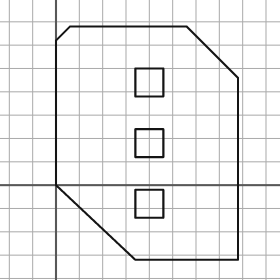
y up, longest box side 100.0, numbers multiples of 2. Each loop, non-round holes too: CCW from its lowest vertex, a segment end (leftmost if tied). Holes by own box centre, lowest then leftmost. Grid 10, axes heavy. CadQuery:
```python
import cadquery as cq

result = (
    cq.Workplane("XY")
    .moveTo(34.0, -32.0)
    .lineTo(78.0, -32.0)
    .lineTo(78.0, 46.0)
    .lineTo(56.0, 68.0)
    .lineTo(6.0, 68.0)
    .lineTo(0.0, 62.0)
    .lineTo(0.0, 0.0)
    .close()
    .moveTo(34.0, -14.0)
    .lineTo(46.0, -14.0)
    .lineTo(46.0, -2.0)
    .lineTo(34.0, -2.0)
    .close()
    .moveTo(34.0, 12.0)
    .lineTo(46.0, 12.0)
    .lineTo(46.0, 24.0)
    .lineTo(34.0, 24.0)
    .close()
    .moveTo(34.0, 38.0)
    .lineTo(46.0, 38.0)
    .lineTo(46.0, 50.0)
    .lineTo(34.0, 50.0)
    .close()
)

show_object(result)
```